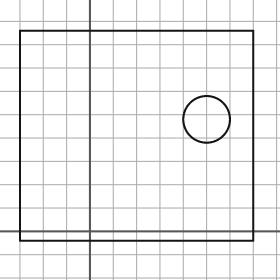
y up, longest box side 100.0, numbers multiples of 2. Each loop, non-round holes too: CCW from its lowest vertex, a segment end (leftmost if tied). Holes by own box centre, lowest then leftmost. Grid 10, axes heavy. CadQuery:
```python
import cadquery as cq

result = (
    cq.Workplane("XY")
    .moveTo(-30.0, -4.0)
    .lineTo(70.0, -4.0)
    .lineTo(70.0, 86.0)
    .lineTo(-30.0, 86.0)
    .close()
    .moveTo(50.0, 48.0)
    .circle(10.0)
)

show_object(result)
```